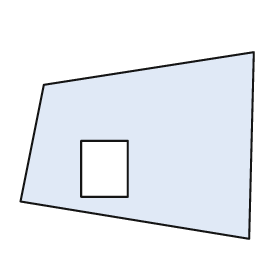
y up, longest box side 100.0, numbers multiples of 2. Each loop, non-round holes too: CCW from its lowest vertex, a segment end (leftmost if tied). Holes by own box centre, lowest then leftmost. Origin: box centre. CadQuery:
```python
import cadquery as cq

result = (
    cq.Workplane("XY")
    .moveTo(48.0, -40.0)
    .lineTo(50.0, 40.0)
    .lineTo(-40.0, 26.0)
    .lineTo(-50.0, -24.0)
    .close()
    .moveTo(-24.0, -22.0)
    .lineTo(-4.0, -22.0)
    .lineTo(-4.0, 2.0)
    .lineTo(-24.0, 2.0)
    .close()
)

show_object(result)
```